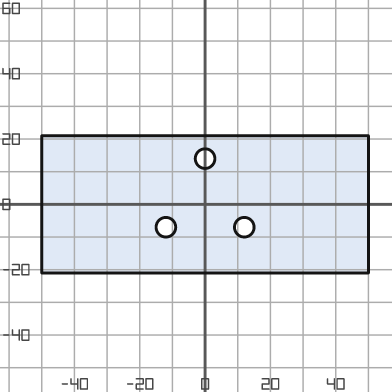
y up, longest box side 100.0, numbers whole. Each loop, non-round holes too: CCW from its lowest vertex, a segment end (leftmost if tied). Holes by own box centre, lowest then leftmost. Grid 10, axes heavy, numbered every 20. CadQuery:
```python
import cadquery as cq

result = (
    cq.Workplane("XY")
    .moveTo(-50.0, -21.0)
    .lineTo(50.0, -21.0)
    .lineTo(50.0, 21.0)
    .lineTo(-50.0, 21.0)
    .close()
    .moveTo(-12.0, -7.0)
    .circle(3.0)
    .moveTo(12.0, -7.0)
    .circle(3.0)
    .moveTo(0.0, 14.0)
    .circle(3.0)
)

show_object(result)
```